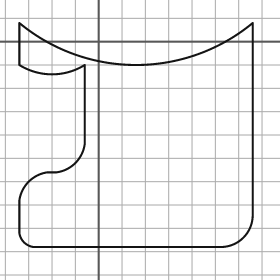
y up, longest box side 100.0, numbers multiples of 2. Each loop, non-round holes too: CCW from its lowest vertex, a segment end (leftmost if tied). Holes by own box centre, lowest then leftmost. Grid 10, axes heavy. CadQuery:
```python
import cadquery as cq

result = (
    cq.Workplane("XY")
    .moveTo(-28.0, -88.0)
    .lineTo(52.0, -88.0)
    .threePointArc((62.0, -84.0), (66.0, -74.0))
    .lineTo(66.0, 8.0)
    .threePointArc((16.0, -10.0), (-34.0, 8.0))
    .lineTo(-34.0, -10.0)
    .threePointArc((-20.0, -14.0), (-6.0, -10.0))
    .lineTo(-6.0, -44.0)
    .threePointArc((-10.0, -52.0), (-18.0, -56.0))
    .lineTo(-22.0, -56.0)
    .threePointArc((-30.0, -60.0), (-34.0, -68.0))
    .lineTo(-34.0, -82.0)
    .threePointArc((-32.0, -86.0), (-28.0, -88.0))
    .close()
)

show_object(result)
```